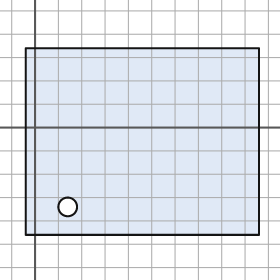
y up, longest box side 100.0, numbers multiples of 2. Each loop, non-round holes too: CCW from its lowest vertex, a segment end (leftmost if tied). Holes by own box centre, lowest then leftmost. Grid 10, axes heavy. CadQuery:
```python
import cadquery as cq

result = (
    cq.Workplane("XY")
    .moveTo(-4.0, -46.0)
    .lineTo(96.0, -46.0)
    .lineTo(96.0, 34.0)
    .lineTo(-4.0, 34.0)
    .close()
    .moveTo(14.0, -34.0)
    .circle(4.0)
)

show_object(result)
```